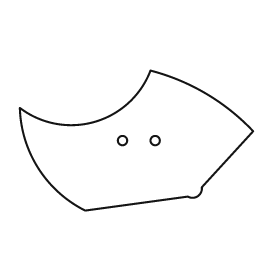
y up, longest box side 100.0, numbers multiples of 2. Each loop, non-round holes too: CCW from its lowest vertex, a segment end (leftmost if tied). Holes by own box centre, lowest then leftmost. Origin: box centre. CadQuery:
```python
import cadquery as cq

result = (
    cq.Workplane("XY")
    .moveTo(-22.0, -30.0)
    .lineTo(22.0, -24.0)
    .threePointArc((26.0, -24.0), (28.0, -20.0))
    .lineTo(50.0, 4.0)
    .threePointArc((30.0, 20.0), (6.0, 30.0))
    .threePointArc((-18.0, 8.0), (-50.0, 14.0))
    .threePointArc((-42.0, -12.0), (-22.0, -30.0))
    .close()
    .moveTo(-6.0, 0.0)
    .circle(2.0)
    .moveTo(8.0, 0.0)
    .circle(2.0)
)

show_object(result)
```